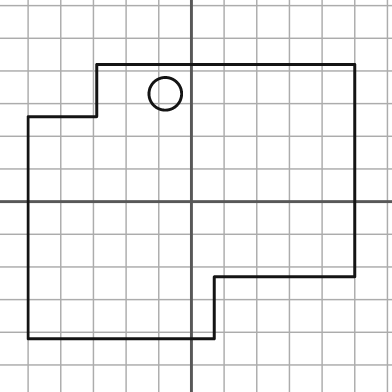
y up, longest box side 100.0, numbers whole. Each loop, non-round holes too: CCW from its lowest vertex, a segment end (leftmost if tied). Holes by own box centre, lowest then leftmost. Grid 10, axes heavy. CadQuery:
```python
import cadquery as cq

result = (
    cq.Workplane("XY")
    .moveTo(-50.0, -42.0)
    .lineTo(7.0, -42.0)
    .lineTo(7.0, -23.0)
    .lineTo(50.0, -23.0)
    .lineTo(50.0, 42.0)
    .lineTo(-29.0, 42.0)
    .lineTo(-29.0, 26.0)
    .lineTo(-50.0, 26.0)
    .close()
    .moveTo(-8.0, 33.0)
    .circle(5.0)
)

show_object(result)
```